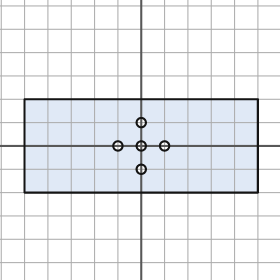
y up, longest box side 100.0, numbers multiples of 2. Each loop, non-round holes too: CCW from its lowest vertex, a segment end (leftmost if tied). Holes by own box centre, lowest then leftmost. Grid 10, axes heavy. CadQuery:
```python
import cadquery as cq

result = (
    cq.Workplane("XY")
    .moveTo(-50.0, -20.0)
    .lineTo(50.0, -20.0)
    .lineTo(50.0, 20.0)
    .lineTo(-50.0, 20.0)
    .close()
    .moveTo(0.0, -10.0)
    .circle(2.0)
    .moveTo(-10.0, 0.0)
    .circle(2.0)
    .moveTo(0.0, 0.0)
    .circle(2.0)
    .moveTo(10.0, 0.0)
    .circle(2.0)
    .moveTo(0.0, 10.0)
    .circle(2.0)
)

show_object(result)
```